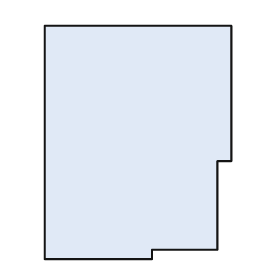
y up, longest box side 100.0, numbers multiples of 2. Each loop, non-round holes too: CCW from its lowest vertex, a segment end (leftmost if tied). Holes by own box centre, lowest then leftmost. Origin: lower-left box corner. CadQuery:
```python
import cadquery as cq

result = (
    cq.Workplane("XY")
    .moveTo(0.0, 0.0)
    .lineTo(46.0, 0.0)
    .lineTo(46.0, 4.0)
    .lineTo(74.0, 4.0)
    .lineTo(74.0, 42.0)
    .lineTo(80.0, 42.0)
    .lineTo(80.0, 100.0)
    .lineTo(0.0, 100.0)
    .close()
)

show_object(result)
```